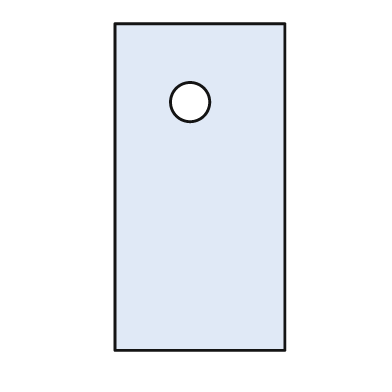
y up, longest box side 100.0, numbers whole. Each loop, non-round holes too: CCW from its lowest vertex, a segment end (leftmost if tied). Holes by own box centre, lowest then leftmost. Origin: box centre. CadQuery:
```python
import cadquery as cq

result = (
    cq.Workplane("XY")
    .moveTo(-26.0, -50.0)
    .lineTo(26.0, -50.0)
    .lineTo(26.0, 50.0)
    .lineTo(-26.0, 50.0)
    .close()
    .moveTo(-3.0, 26.0)
    .circle(6.0)
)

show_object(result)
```